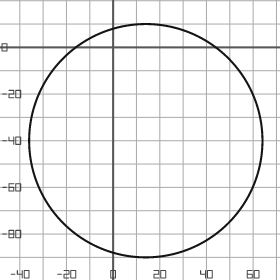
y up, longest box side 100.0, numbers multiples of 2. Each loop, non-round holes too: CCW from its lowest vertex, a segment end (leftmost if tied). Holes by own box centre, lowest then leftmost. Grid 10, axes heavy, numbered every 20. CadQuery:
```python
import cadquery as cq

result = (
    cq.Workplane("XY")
    .moveTo(14.0, -40.0)
    .circle(50.0)
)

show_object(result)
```